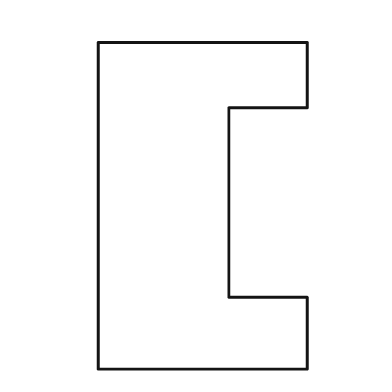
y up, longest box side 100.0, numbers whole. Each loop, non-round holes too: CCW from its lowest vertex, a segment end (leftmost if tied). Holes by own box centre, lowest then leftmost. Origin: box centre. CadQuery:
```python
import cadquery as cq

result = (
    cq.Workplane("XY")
    .moveTo(-32.0, -50.0)
    .lineTo(32.0, -50.0)
    .lineTo(32.0, -28.0)
    .lineTo(8.0, -28.0)
    .lineTo(8.0, 30.0)
    .lineTo(32.0, 30.0)
    .lineTo(32.0, 50.0)
    .lineTo(-32.0, 50.0)
    .close()
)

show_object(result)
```